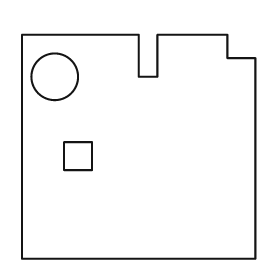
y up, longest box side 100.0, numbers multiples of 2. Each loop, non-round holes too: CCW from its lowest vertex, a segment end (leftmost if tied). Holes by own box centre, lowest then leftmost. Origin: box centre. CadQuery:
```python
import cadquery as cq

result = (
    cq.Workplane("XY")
    .moveTo(-50.0, -48.0)
    .lineTo(50.0, -48.0)
    .lineTo(50.0, 38.0)
    .lineTo(38.0, 38.0)
    .lineTo(38.0, 48.0)
    .lineTo(8.0, 48.0)
    .lineTo(8.0, 30.0)
    .lineTo(0.0, 30.0)
    .lineTo(0.0, 48.0)
    .lineTo(-50.0, 48.0)
    .close()
    .moveTo(-32.0, -10.0)
    .lineTo(-20.0, -10.0)
    .lineTo(-20.0, 2.0)
    .lineTo(-32.0, 2.0)
    .close()
    .moveTo(-36.0, 30.0)
    .circle(10.0)
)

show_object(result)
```